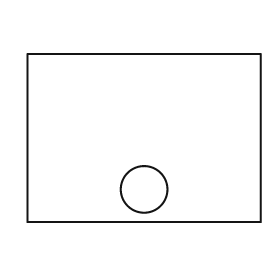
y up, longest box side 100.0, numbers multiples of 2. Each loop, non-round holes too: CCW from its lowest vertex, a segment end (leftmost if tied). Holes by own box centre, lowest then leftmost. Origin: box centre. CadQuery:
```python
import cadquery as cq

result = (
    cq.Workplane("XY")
    .moveTo(-50.0, -36.0)
    .lineTo(50.0, -36.0)
    .lineTo(50.0, 36.0)
    .lineTo(-50.0, 36.0)
    .close()
    .moveTo(0.0, -22.0)
    .circle(10.0)
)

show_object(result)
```